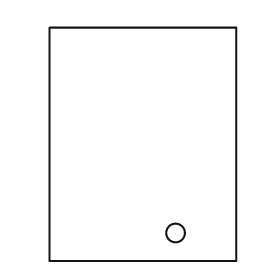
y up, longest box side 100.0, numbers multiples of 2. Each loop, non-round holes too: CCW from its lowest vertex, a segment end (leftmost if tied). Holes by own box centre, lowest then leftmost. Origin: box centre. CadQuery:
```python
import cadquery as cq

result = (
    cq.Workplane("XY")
    .moveTo(-40.0, -50.0)
    .lineTo(40.0, -50.0)
    .lineTo(40.0, 50.0)
    .lineTo(-40.0, 50.0)
    .close()
    .moveTo(14.0, -38.0)
    .circle(4.0)
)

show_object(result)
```